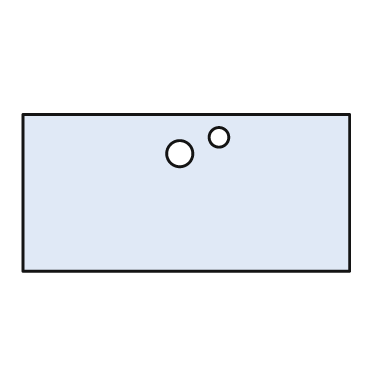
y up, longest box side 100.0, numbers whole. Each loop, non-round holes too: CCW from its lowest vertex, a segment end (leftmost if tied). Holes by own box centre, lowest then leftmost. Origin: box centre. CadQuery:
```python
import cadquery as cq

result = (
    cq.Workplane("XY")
    .moveTo(-50.0, -24.0)
    .lineTo(50.0, -24.0)
    .lineTo(50.0, 24.0)
    .lineTo(-50.0, 24.0)
    .close()
    .moveTo(-2.0, 12.0)
    .circle(4.0)
    .moveTo(10.0, 17.0)
    .circle(3.0)
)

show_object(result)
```